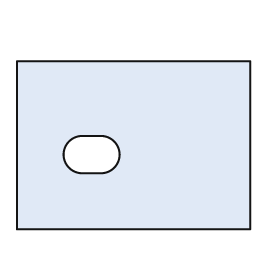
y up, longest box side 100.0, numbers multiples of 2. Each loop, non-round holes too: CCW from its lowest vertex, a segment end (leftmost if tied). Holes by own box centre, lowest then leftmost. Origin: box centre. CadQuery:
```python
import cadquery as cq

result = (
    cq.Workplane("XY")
    .moveTo(-50.0, -36.0)
    .lineTo(50.0, -36.0)
    .lineTo(50.0, 36.0)
    .lineTo(-50.0, 36.0)
    .close()
    .moveTo(-22.0, -12.0)
    .lineTo(-14.0, -12.0)
    .threePointArc((-6.0, -4.0), (-14.0, 4.0))
    .lineTo(-22.0, 4.0)
    .threePointArc((-30.0, -4.0), (-22.0, -12.0))
    .close()
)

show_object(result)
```